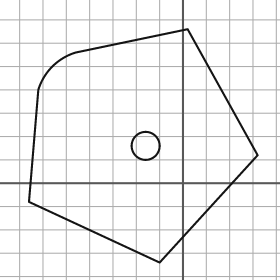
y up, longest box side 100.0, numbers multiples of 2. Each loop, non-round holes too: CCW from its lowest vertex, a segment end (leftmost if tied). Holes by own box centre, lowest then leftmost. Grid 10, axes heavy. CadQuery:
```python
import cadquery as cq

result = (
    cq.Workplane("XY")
    .moveTo(-10.0, -34.0)
    .lineTo(32.0, 12.0)
    .lineTo(2.0, 66.0)
    .lineTo(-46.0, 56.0)
    .threePointArc((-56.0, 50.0), (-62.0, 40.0))
    .lineTo(-66.0, -8.0)
    .close()
    .moveTo(-16.0, 16.0)
    .circle(6.0)
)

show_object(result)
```